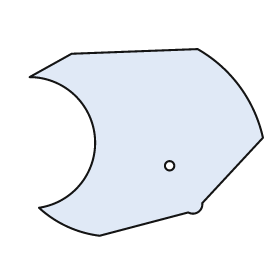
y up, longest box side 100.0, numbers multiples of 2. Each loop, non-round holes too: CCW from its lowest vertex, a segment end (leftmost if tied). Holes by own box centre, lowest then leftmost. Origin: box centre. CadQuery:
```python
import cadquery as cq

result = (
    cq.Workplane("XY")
    .moveTo(-20.0, -40.0)
    .lineTo(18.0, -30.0)
    .threePointArc((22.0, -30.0), (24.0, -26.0))
    .lineTo(50.0, 2.0)
    .threePointArc((40.0, 24.0), (22.0, 40.0))
    .lineTo(-32.0, 38.0)
    .lineTo(-50.0, 28.0)
    .threePointArc((-22.0, 2.0), (-46.0, -28.0))
    .threePointArc((-34.0, -36.0), (-20.0, -40.0))
    .close()
    .moveTo(10.0, -10.0)
    .circle(2.0)
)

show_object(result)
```